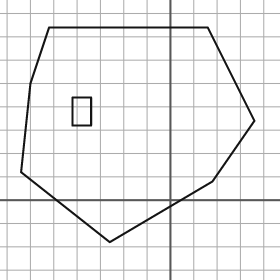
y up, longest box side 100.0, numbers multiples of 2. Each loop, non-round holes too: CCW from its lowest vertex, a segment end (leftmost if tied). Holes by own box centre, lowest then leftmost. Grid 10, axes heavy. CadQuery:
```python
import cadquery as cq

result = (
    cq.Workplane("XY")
    .moveTo(-26.0, -18.0)
    .lineTo(18.0, 8.0)
    .lineTo(36.0, 34.0)
    .lineTo(16.0, 74.0)
    .lineTo(-52.0, 74.0)
    .lineTo(-60.0, 50.0)
    .lineTo(-64.0, 12.0)
    .close()
    .moveTo(-42.0, 32.0)
    .lineTo(-34.0, 32.0)
    .lineTo(-34.0, 44.0)
    .lineTo(-42.0, 44.0)
    .close()
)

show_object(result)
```